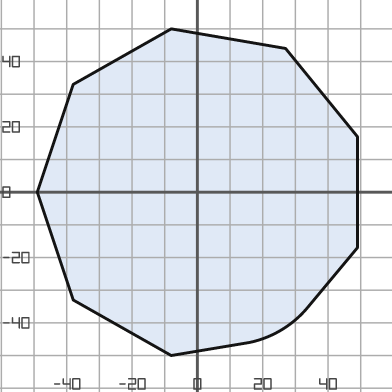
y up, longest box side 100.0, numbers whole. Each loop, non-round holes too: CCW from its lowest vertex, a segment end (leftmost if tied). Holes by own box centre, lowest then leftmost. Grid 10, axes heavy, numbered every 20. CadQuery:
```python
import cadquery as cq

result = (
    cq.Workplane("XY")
    .moveTo(-8.0, -50.0)
    .lineTo(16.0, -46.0)
    .threePointArc((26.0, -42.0), (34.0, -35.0))
    .lineTo(49.0, -17.0)
    .lineTo(49.0, 17.0)
    .lineTo(27.0, 44.0)
    .lineTo(-8.0, 50.0)
    .lineTo(-38.0, 33.0)
    .lineTo(-49.0, 0.0)
    .lineTo(-38.0, -33.0)
    .close()
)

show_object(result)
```